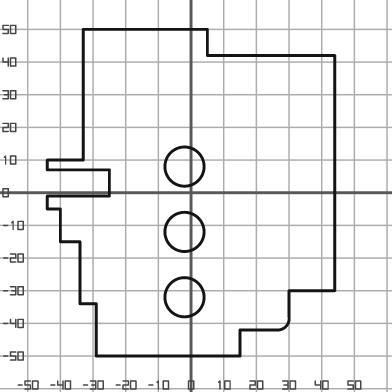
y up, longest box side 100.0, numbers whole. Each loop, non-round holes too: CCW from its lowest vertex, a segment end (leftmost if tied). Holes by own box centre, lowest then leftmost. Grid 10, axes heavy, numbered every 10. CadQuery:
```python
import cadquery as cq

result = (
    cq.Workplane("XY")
    .moveTo(-29.0, -50.0)
    .lineTo(15.0, -50.0)
    .lineTo(15.0, -42.0)
    .lineTo(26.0, -42.0)
    .threePointArc((29.0, -41.0), (30.0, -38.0))
    .lineTo(30.0, -30.0)
    .lineTo(44.0, -30.0)
    .lineTo(44.0, 42.0)
    .lineTo(5.0, 42.0)
    .lineTo(5.0, 50.0)
    .lineTo(-33.0, 50.0)
    .lineTo(-33.0, 10.0)
    .lineTo(-44.0, 10.0)
    .lineTo(-44.0, 7.0)
    .lineTo(-25.0, 7.0)
    .lineTo(-25.0, -1.0)
    .lineTo(-44.0, -1.0)
    .lineTo(-44.0, -5.0)
    .lineTo(-40.0, -5.0)
    .lineTo(-40.0, -15.0)
    .lineTo(-34.0, -15.0)
    .lineTo(-34.0, -34.0)
    .lineTo(-29.0, -34.0)
    .close()
    .moveTo(-2.0, -32.0)
    .circle(6.0)
    .moveTo(-2.0, -12.0)
    .circle(6.0)
    .moveTo(-2.0, 8.0)
    .circle(6.0)
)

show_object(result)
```